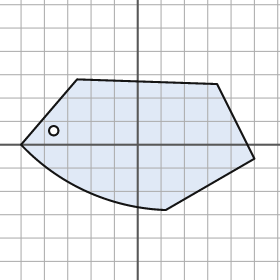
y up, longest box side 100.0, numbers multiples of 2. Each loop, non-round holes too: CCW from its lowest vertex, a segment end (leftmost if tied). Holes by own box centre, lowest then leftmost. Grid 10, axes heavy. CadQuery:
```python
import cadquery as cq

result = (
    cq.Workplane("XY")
    .moveTo(12.0, -28.0)
    .lineTo(50.0, -6.0)
    .lineTo(34.0, 26.0)
    .lineTo(-26.0, 28.0)
    .lineTo(-50.0, 0.0)
    .threePointArc((-22.0, -20.0), (12.0, -28.0))
    .close()
    .moveTo(-36.0, 6.0)
    .circle(2.0)
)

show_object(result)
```